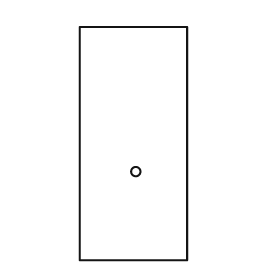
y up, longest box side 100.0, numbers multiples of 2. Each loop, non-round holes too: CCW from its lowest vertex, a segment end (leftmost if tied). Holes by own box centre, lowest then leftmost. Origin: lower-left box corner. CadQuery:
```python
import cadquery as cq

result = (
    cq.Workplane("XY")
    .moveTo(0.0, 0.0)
    .lineTo(46.0, 0.0)
    .lineTo(46.0, 100.0)
    .lineTo(0.0, 100.0)
    .close()
    .moveTo(24.0, 38.0)
    .circle(2.0)
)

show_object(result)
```